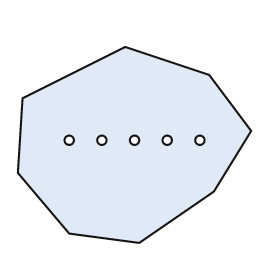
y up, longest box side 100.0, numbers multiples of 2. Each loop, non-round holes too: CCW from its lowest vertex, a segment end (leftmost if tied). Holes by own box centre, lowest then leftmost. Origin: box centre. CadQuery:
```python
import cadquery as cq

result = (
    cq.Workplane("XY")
    .moveTo(2.0, -42.0)
    .lineTo(34.0, -20.0)
    .lineTo(50.0, 6.0)
    .lineTo(32.0, 30.0)
    .lineTo(-4.0, 42.0)
    .lineTo(-48.0, 20.0)
    .lineTo(-50.0, -12.0)
    .lineTo(-28.0, -38.0)
    .close()
    .moveTo(-28.0, 2.0)
    .circle(2.0)
    .moveTo(-14.0, 2.0)
    .circle(2.0)
    .moveTo(0.0, 2.0)
    .circle(2.0)
    .moveTo(14.0, 2.0)
    .circle(2.0)
    .moveTo(28.0, 2.0)
    .circle(2.0)
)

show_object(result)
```